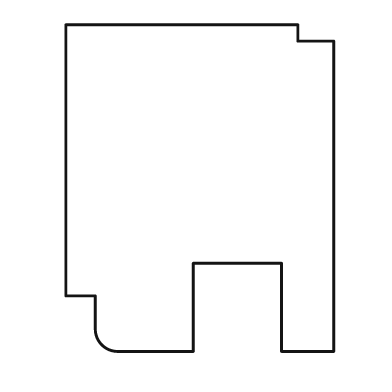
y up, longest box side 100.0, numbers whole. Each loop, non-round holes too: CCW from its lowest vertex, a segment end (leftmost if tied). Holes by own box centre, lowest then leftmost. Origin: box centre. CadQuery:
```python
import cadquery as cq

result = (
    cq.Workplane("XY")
    .moveTo(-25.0, -50.0)
    .lineTo(-2.0, -50.0)
    .lineTo(-2.0, -23.0)
    .lineTo(25.0, -23.0)
    .lineTo(25.0, -50.0)
    .lineTo(41.0, -50.0)
    .lineTo(41.0, 45.0)
    .lineTo(30.0, 45.0)
    .lineTo(30.0, 50.0)
    .lineTo(-41.0, 50.0)
    .lineTo(-41.0, -33.0)
    .lineTo(-32.0, -33.0)
    .lineTo(-32.0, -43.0)
    .threePointArc((-30.0, -48.0), (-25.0, -50.0))
    .close()
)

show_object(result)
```